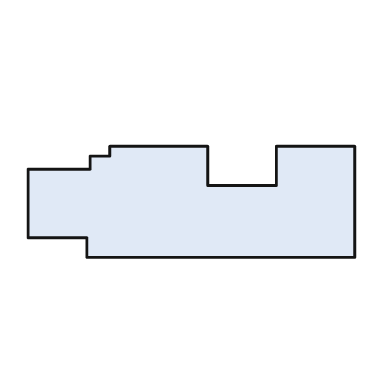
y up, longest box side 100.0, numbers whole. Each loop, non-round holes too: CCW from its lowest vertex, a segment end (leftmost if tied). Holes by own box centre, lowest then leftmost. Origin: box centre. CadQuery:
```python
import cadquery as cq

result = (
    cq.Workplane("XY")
    .moveTo(-32.0, -17.0)
    .lineTo(50.0, -17.0)
    .lineTo(50.0, 17.0)
    .lineTo(26.0, 17.0)
    .lineTo(26.0, 5.0)
    .lineTo(5.0, 5.0)
    .lineTo(5.0, 17.0)
    .lineTo(-25.0, 17.0)
    .lineTo(-25.0, 14.0)
    .lineTo(-31.0, 14.0)
    .lineTo(-31.0, 10.0)
    .lineTo(-50.0, 10.0)
    .lineTo(-50.0, -11.0)
    .lineTo(-32.0, -11.0)
    .close()
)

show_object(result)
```